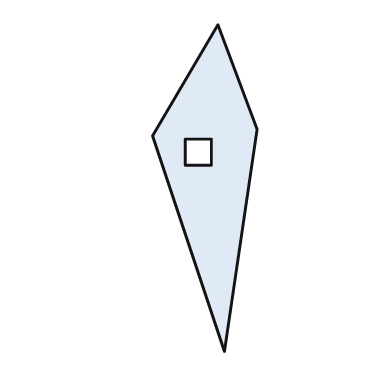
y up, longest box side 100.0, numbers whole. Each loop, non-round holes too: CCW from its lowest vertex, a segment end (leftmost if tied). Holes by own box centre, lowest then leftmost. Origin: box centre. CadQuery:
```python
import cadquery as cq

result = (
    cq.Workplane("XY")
    .moveTo(6.0, -50.0)
    .lineTo(16.0, 18.0)
    .lineTo(4.0, 50.0)
    .lineTo(-16.0, 16.0)
    .close()
    .moveTo(-6.0, 7.0)
    .lineTo(2.0, 7.0)
    .lineTo(2.0, 15.0)
    .lineTo(-6.0, 15.0)
    .close()
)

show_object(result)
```